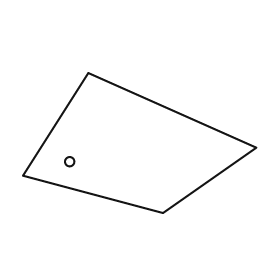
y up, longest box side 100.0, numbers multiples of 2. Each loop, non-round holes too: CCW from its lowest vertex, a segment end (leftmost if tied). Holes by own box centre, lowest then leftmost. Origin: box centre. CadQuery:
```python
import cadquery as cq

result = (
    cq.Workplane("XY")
    .moveTo(10.0, -30.0)
    .lineTo(50.0, -2.0)
    .lineTo(-22.0, 30.0)
    .lineTo(-50.0, -14.0)
    .close()
    .moveTo(-30.0, -8.0)
    .circle(2.0)
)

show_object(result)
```